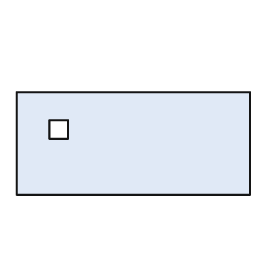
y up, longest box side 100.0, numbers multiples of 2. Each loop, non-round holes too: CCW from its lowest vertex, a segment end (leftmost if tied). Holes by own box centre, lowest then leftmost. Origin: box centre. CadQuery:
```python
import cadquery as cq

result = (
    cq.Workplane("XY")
    .moveTo(-50.0, -22.0)
    .lineTo(50.0, -22.0)
    .lineTo(50.0, 22.0)
    .lineTo(-50.0, 22.0)
    .close()
    .moveTo(-36.0, 2.0)
    .lineTo(-28.0, 2.0)
    .lineTo(-28.0, 10.0)
    .lineTo(-36.0, 10.0)
    .close()
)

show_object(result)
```